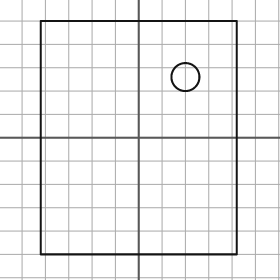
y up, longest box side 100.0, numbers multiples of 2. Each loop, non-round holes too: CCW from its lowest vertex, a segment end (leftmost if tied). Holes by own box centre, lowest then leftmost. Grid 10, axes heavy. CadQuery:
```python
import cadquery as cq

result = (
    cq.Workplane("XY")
    .moveTo(-42.0, -50.0)
    .lineTo(42.0, -50.0)
    .lineTo(42.0, 50.0)
    .lineTo(-42.0, 50.0)
    .close()
    .moveTo(20.0, 26.0)
    .circle(6.0)
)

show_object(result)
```